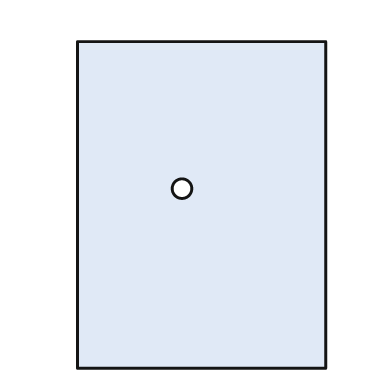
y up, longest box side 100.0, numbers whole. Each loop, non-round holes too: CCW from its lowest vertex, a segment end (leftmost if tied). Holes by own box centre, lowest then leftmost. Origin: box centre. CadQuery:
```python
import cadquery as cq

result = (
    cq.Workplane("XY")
    .moveTo(-38.0, -50.0)
    .lineTo(38.0, -50.0)
    .lineTo(38.0, 50.0)
    .lineTo(-38.0, 50.0)
    .close()
    .moveTo(-6.0, 5.0)
    .circle(3.0)
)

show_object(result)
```